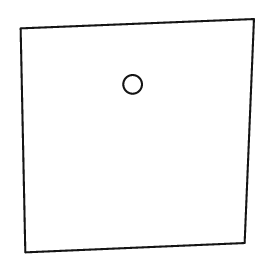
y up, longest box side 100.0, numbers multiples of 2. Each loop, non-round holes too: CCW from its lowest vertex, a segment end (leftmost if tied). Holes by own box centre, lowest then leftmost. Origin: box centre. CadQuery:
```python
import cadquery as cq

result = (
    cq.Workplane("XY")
    .moveTo(-48.0, -50.0)
    .lineTo(46.0, -46.0)
    .lineTo(50.0, 50.0)
    .lineTo(-50.0, 46.0)
    .close()
    .moveTo(-2.0, 22.0)
    .circle(4.0)
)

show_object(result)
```